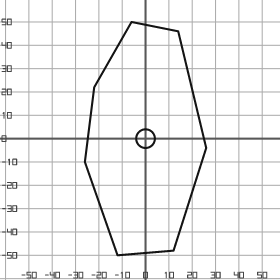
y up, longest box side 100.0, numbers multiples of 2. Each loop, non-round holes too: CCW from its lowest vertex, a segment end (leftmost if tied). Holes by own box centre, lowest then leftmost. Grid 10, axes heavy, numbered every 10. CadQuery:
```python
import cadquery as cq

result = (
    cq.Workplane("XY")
    .moveTo(-12.0, -50.0)
    .lineTo(12.0, -48.0)
    .lineTo(26.0, -4.0)
    .lineTo(14.0, 46.0)
    .lineTo(-6.0, 50.0)
    .lineTo(-22.0, 22.0)
    .lineTo(-26.0, -10.0)
    .close()
    .moveTo(0.0, 0.0)
    .circle(4.0)
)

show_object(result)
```